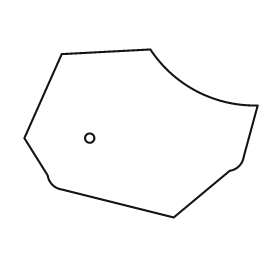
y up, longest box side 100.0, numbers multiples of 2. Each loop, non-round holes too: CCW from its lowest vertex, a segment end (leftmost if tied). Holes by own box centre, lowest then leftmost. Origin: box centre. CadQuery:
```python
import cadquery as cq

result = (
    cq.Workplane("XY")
    .moveTo(14.0, -36.0)
    .lineTo(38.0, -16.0)
    .threePointArc((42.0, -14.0), (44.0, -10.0))
    .lineTo(50.0, 12.0)
    .threePointArc((24.0, 18.0), (4.0, 36.0))
    .lineTo(-34.0, 34.0)
    .lineTo(-50.0, -2.0)
    .lineTo(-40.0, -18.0)
    .threePointArc((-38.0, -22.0), (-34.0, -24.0))
    .close()
    .moveTo(-22.0, -2.0)
    .circle(2.0)
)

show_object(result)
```